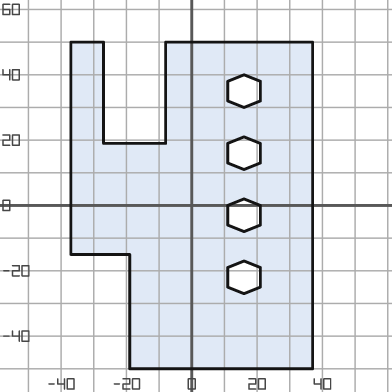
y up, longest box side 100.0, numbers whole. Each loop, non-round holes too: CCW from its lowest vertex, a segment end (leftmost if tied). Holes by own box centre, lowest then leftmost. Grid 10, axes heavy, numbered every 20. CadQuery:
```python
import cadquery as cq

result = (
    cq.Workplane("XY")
    .moveTo(-19.0, -50.0)
    .lineTo(37.0, -50.0)
    .lineTo(37.0, 50.0)
    .lineTo(-8.0, 50.0)
    .lineTo(-8.0, 19.0)
    .lineTo(-27.0, 19.0)
    .lineTo(-27.0, 50.0)
    .lineTo(-37.0, 50.0)
    .lineTo(-37.0, -15.0)
    .lineTo(-19.0, -15.0)
    .close()
    .moveTo(16.0, -27.0)
    .lineTo(21.0, -25.0)
    .lineTo(21.0, -19.0)
    .lineTo(16.0, -17.0)
    .lineTo(11.0, -19.0)
    .lineTo(11.0, -25.0)
    .close()
    .moveTo(16.0, -8.0)
    .lineTo(21.0, -6.0)
    .lineTo(21.0, 0.0)
    .lineTo(16.0, 2.0)
    .lineTo(11.0, 0.0)
    .lineTo(11.0, -6.0)
    .close()
    .moveTo(16.0, 11.0)
    .lineTo(21.0, 13.0)
    .lineTo(21.0, 19.0)
    .lineTo(16.0, 21.0)
    .lineTo(11.0, 19.0)
    .lineTo(11.0, 13.0)
    .close()
    .moveTo(16.0, 30.0)
    .lineTo(21.0, 32.0)
    .lineTo(21.0, 38.0)
    .lineTo(16.0, 40.0)
    .lineTo(11.0, 38.0)
    .lineTo(11.0, 32.0)
    .close()
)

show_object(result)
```